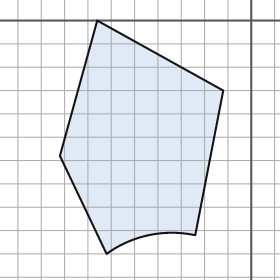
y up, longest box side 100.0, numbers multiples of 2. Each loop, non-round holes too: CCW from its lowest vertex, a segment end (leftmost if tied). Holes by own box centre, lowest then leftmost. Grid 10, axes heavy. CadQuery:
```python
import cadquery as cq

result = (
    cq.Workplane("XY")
    .moveTo(-62.0, -100.0)
    .threePointArc((-44.0, -92.0), (-24.0, -92.0))
    .lineTo(-12.0, -30.0)
    .lineTo(-66.0, 0.0)
    .lineTo(-82.0, -58.0)
    .close()
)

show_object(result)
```